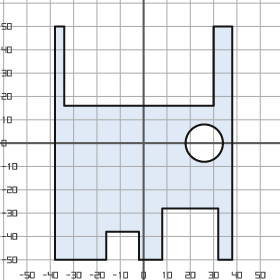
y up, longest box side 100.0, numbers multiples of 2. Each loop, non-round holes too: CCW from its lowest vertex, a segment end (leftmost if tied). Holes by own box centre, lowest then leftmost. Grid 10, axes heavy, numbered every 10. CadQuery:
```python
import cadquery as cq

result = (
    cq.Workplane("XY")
    .moveTo(-38.0, -50.0)
    .lineTo(-16.0, -50.0)
    .lineTo(-16.0, -38.0)
    .lineTo(-2.0, -38.0)
    .lineTo(-2.0, -50.0)
    .lineTo(8.0, -50.0)
    .lineTo(8.0, -28.0)
    .lineTo(32.0, -28.0)
    .lineTo(32.0, -50.0)
    .lineTo(38.0, -50.0)
    .lineTo(38.0, 50.0)
    .lineTo(30.0, 50.0)
    .lineTo(30.0, 16.0)
    .lineTo(-34.0, 16.0)
    .lineTo(-34.0, 50.0)
    .lineTo(-38.0, 50.0)
    .close()
    .moveTo(26.0, 0.0)
    .circle(8.0)
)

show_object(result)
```